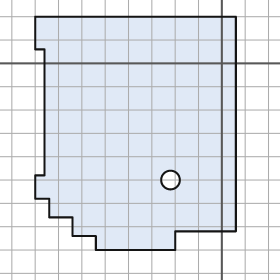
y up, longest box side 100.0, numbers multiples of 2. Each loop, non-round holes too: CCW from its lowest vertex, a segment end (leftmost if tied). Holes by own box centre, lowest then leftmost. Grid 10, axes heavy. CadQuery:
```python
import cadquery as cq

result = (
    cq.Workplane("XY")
    .moveTo(-54.0, -80.0)
    .lineTo(-20.0, -80.0)
    .lineTo(-20.0, -72.0)
    .lineTo(6.0, -72.0)
    .lineTo(6.0, 20.0)
    .lineTo(-80.0, 20.0)
    .lineTo(-80.0, 6.0)
    .lineTo(-76.0, 6.0)
    .lineTo(-76.0, -48.0)
    .lineTo(-80.0, -48.0)
    .lineTo(-80.0, -58.0)
    .lineTo(-74.0, -58.0)
    .lineTo(-74.0, -66.0)
    .lineTo(-64.0, -66.0)
    .lineTo(-64.0, -74.0)
    .lineTo(-54.0, -74.0)
    .close()
    .moveTo(-22.0, -50.0)
    .circle(4.0)
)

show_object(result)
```